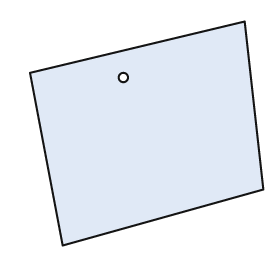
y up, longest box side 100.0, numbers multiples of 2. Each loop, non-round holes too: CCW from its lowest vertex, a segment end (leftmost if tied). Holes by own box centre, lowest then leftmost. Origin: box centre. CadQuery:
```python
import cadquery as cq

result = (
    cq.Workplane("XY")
    .moveTo(-36.0, -48.0)
    .lineTo(50.0, -24.0)
    .lineTo(42.0, 48.0)
    .lineTo(-50.0, 26.0)
    .close()
    .moveTo(-10.0, 24.0)
    .circle(2.0)
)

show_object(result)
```